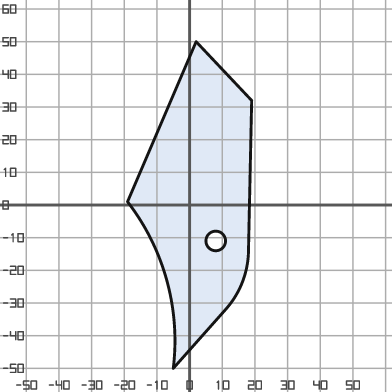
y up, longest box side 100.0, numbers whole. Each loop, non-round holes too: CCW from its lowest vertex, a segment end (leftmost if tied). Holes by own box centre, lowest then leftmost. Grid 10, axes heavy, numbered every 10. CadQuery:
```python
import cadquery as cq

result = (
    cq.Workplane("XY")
    .moveTo(-5.0, -50.0)
    .lineTo(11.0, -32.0)
    .threePointArc((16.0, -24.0), (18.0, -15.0))
    .lineTo(19.0, 32.0)
    .lineTo(2.0, 50.0)
    .lineTo(-19.0, 1.0)
    .threePointArc((-7.0, -23.0), (-5.0, -50.0))
    .close()
    .moveTo(8.0, -11.0)
    .circle(3.0)
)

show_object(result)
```